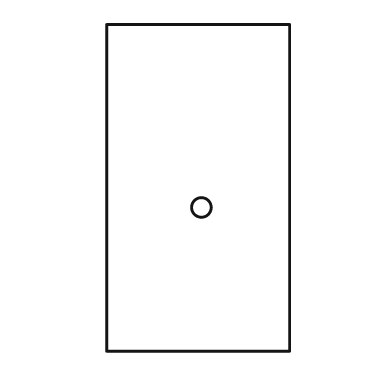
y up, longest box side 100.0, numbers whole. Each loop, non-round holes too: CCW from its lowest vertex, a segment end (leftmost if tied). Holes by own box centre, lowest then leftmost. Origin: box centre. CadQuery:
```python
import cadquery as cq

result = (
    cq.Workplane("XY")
    .moveTo(-28.0, -50.0)
    .lineTo(28.0, -50.0)
    .lineTo(28.0, 50.0)
    .lineTo(-28.0, 50.0)
    .close()
    .moveTo(1.0, -6.0)
    .circle(3.0)
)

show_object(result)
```